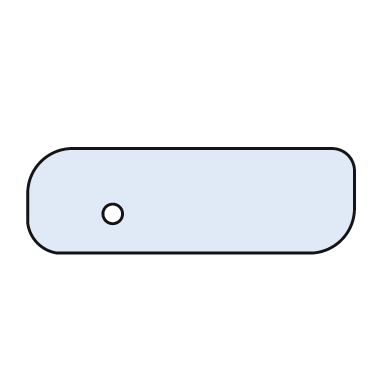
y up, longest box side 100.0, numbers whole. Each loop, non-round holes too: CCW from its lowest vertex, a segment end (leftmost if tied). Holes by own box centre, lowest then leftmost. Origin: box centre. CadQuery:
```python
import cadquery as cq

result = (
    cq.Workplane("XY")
    .moveTo(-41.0, -16.0)
    .lineTo(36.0, -16.0)
    .threePointArc((46.0, -12.0), (50.0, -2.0))
    .lineTo(50.0, 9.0)
    .threePointArc((48.0, 14.0), (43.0, 16.0))
    .lineTo(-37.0, 16.0)
    .threePointArc((-46.0, 12.0), (-50.0, 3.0))
    .lineTo(-50.0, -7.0)
    .threePointArc((-47.0, -13.0), (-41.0, -16.0))
    .close()
    .moveTo(-24.0, -4.0)
    .circle(3.0)
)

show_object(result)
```